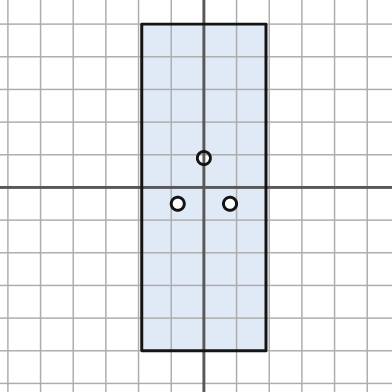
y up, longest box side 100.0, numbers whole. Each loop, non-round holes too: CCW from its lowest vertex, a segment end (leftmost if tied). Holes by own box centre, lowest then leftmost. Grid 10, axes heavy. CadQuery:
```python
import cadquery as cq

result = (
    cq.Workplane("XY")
    .moveTo(-19.0, -50.0)
    .lineTo(19.0, -50.0)
    .lineTo(19.0, 50.0)
    .lineTo(-19.0, 50.0)
    .close()
    .moveTo(-8.0, -5.0)
    .circle(2.0)
    .moveTo(8.0, -5.0)
    .circle(2.0)
    .moveTo(0.0, 9.0)
    .circle(2.0)
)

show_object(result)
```